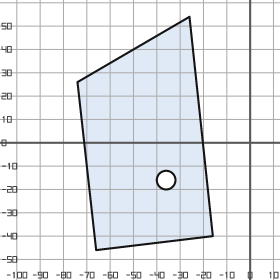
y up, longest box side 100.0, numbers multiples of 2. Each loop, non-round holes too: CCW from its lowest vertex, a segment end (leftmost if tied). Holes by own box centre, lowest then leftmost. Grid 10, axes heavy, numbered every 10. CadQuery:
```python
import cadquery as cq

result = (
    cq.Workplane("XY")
    .moveTo(-66.0, -46.0)
    .lineTo(-16.0, -40.0)
    .lineTo(-26.0, 54.0)
    .lineTo(-74.0, 26.0)
    .close()
    .moveTo(-36.0, -16.0)
    .circle(4.0)
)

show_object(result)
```